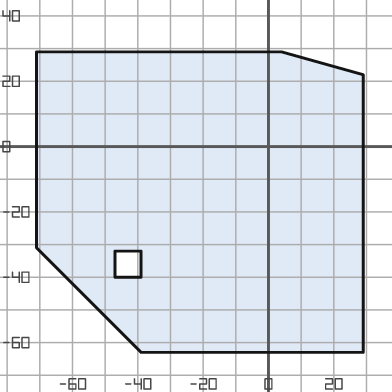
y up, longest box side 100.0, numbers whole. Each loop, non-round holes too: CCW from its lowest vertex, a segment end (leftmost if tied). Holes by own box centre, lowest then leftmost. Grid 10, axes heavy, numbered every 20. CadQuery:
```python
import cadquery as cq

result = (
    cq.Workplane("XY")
    .moveTo(-39.0, -63.0)
    .lineTo(29.0, -63.0)
    .lineTo(29.0, 22.0)
    .lineTo(4.0, 29.0)
    .lineTo(-71.0, 29.0)
    .lineTo(-71.0, -31.0)
    .close()
    .moveTo(-47.0, -40.0)
    .lineTo(-39.0, -40.0)
    .lineTo(-39.0, -32.0)
    .lineTo(-47.0, -32.0)
    .close()
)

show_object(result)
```